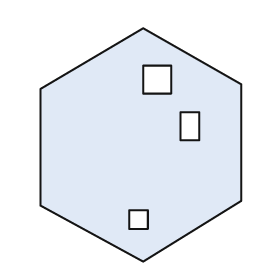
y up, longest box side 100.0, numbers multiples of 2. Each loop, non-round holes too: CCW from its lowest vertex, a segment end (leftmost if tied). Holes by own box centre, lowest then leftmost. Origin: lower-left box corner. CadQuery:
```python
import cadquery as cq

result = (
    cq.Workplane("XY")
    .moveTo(44.0, 0.0)
    .lineTo(86.0, 26.0)
    .lineTo(86.0, 76.0)
    .lineTo(44.0, 100.0)
    .lineTo(0.0, 74.0)
    .lineTo(0.0, 24.0)
    .close()
    .moveTo(38.0, 14.0)
    .lineTo(46.0, 14.0)
    .lineTo(46.0, 22.0)
    .lineTo(38.0, 22.0)
    .close()
    .moveTo(60.0, 52.0)
    .lineTo(68.0, 52.0)
    .lineTo(68.0, 64.0)
    .lineTo(60.0, 64.0)
    .close()
    .moveTo(44.0, 72.0)
    .lineTo(56.0, 72.0)
    .lineTo(56.0, 84.0)
    .lineTo(44.0, 84.0)
    .close()
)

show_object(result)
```